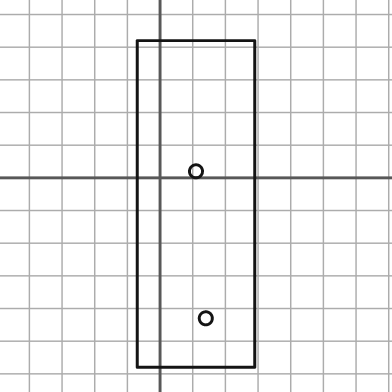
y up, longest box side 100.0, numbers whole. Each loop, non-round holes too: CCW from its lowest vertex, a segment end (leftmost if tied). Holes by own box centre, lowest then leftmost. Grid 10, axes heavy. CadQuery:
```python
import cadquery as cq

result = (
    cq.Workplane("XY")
    .moveTo(-7.0, -58.0)
    .lineTo(29.0, -58.0)
    .lineTo(29.0, 42.0)
    .lineTo(-7.0, 42.0)
    .close()
    .moveTo(14.0, -43.0)
    .circle(2.0)
    .moveTo(11.0, 2.0)
    .circle(2.0)
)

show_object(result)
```